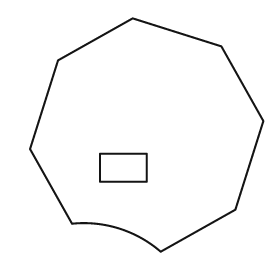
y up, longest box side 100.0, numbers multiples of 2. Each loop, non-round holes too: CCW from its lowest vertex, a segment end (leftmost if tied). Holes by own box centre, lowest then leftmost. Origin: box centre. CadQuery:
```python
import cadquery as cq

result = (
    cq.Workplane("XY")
    .moveTo(6.0, -50.0)
    .lineTo(38.0, -32.0)
    .lineTo(50.0, 6.0)
    .lineTo(32.0, 38.0)
    .lineTo(-6.0, 50.0)
    .lineTo(-38.0, 32.0)
    .lineTo(-50.0, -6.0)
    .lineTo(-32.0, -38.0)
    .threePointArc((-12.0, -40.0), (6.0, -50.0))
    .close()
    .moveTo(-20.0, -20.0)
    .lineTo(0.0, -20.0)
    .lineTo(0.0, -8.0)
    .lineTo(-20.0, -8.0)
    .close()
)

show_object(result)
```